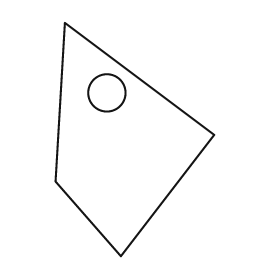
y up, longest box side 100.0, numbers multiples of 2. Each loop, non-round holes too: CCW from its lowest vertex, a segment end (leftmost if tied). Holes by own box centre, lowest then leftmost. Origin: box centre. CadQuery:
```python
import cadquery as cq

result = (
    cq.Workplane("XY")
    .moveTo(-6.0, -50.0)
    .lineTo(34.0, 2.0)
    .lineTo(-30.0, 50.0)
    .lineTo(-34.0, -18.0)
    .close()
    .moveTo(-12.0, 20.0)
    .circle(8.0)
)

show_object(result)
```